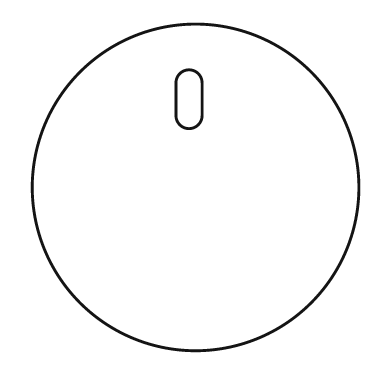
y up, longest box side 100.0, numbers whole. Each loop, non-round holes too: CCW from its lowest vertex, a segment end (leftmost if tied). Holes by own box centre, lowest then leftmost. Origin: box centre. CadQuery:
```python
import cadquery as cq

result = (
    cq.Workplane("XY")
    .moveTo(0.0, 0.0)
    .circle(50.0)
    .moveTo(-6.0, 22.0)
    .threePointArc((-2.0, 18.0), (2.0, 22.0))
    .lineTo(2.0, 32.0)
    .threePointArc((-2.0, 36.0), (-6.0, 32.0))
    .close()
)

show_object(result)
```